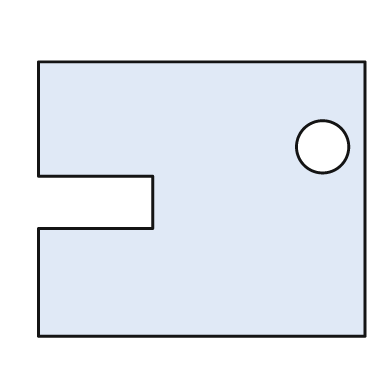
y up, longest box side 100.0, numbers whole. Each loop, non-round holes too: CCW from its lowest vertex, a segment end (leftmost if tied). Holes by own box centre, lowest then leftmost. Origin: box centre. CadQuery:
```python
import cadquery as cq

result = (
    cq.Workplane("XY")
    .moveTo(-50.0, -42.0)
    .lineTo(50.0, -42.0)
    .lineTo(50.0, 42.0)
    .lineTo(-50.0, 42.0)
    .lineTo(-50.0, 7.0)
    .lineTo(-15.0, 7.0)
    .lineTo(-15.0, -9.0)
    .lineTo(-50.0, -9.0)
    .close()
    .moveTo(37.0, 16.0)
    .circle(8.0)
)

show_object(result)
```